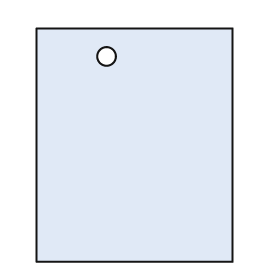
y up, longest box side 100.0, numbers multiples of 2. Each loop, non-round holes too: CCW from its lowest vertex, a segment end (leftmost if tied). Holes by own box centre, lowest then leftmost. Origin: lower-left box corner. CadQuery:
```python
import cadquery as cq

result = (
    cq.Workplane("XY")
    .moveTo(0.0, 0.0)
    .lineTo(84.0, 0.0)
    .lineTo(84.0, 100.0)
    .lineTo(0.0, 100.0)
    .close()
    .moveTo(30.0, 88.0)
    .circle(4.0)
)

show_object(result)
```